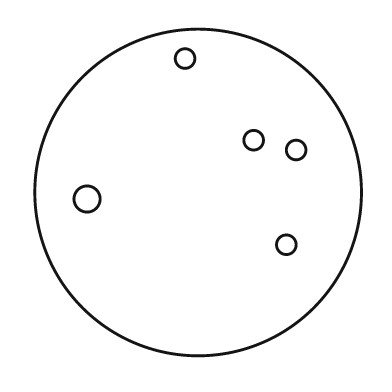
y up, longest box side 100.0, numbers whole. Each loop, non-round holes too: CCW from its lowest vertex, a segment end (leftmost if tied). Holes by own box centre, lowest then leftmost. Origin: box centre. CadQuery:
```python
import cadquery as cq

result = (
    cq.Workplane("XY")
    .moveTo(0.0, 0.0)
    .circle(50.0)
    .moveTo(27.0, -16.0)
    .circle(3.0)
    .moveTo(-34.0, -2.0)
    .circle(4.0)
    .moveTo(30.0, 13.0)
    .circle(3.0)
    .moveTo(17.0, 16.0)
    .circle(3.0)
    .moveTo(-4.0, 41.0)
    .circle(3.0)
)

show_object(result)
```